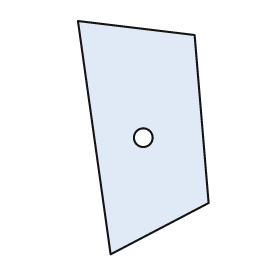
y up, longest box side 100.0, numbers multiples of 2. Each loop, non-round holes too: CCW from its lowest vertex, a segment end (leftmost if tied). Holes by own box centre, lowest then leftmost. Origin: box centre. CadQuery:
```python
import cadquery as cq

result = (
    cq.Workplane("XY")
    .moveTo(-14.0, -50.0)
    .lineTo(28.0, -28.0)
    .lineTo(22.0, 44.0)
    .lineTo(-28.0, 50.0)
    .close()
    .moveTo(0.0, 0.0)
    .circle(4.0)
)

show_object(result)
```